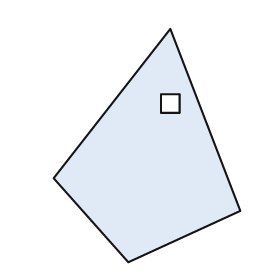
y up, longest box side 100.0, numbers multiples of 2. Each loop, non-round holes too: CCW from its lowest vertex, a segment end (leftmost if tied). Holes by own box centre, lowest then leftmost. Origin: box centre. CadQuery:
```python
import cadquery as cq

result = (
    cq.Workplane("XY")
    .moveTo(-8.0, -50.0)
    .lineTo(40.0, -28.0)
    .lineTo(10.0, 50.0)
    .lineTo(-40.0, -14.0)
    .close()
    .moveTo(6.0, 14.0)
    .lineTo(14.0, 14.0)
    .lineTo(14.0, 22.0)
    .lineTo(6.0, 22.0)
    .close()
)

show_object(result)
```